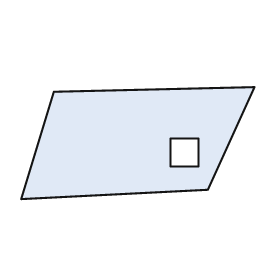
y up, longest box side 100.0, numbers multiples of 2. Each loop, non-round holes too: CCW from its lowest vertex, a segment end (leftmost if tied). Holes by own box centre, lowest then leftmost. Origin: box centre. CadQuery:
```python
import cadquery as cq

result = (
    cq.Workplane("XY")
    .moveTo(-50.0, -24.0)
    .lineTo(30.0, -20.0)
    .lineTo(50.0, 24.0)
    .lineTo(-36.0, 22.0)
    .close()
    .moveTo(14.0, -10.0)
    .lineTo(26.0, -10.0)
    .lineTo(26.0, 2.0)
    .lineTo(14.0, 2.0)
    .close()
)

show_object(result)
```